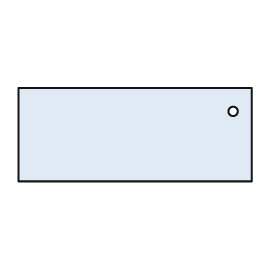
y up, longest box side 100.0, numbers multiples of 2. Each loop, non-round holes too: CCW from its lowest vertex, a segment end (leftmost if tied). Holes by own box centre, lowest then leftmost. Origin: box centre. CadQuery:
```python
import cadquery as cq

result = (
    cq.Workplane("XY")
    .moveTo(-50.0, -20.0)
    .lineTo(50.0, -20.0)
    .lineTo(50.0, 20.0)
    .lineTo(-50.0, 20.0)
    .close()
    .moveTo(42.0, 10.0)
    .circle(2.0)
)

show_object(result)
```